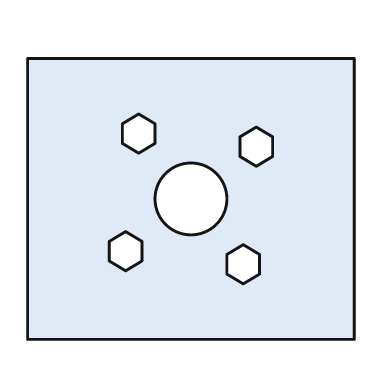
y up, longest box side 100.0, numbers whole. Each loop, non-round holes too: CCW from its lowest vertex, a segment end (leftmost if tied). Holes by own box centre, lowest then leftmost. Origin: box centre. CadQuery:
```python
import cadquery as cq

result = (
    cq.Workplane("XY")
    .moveTo(-50.0, -43.0)
    .lineTo(50.0, -43.0)
    .lineTo(50.0, 43.0)
    .lineTo(-50.0, 43.0)
    .close()
    .moveTo(16.0, -26.0)
    .lineTo(21.0, -23.0)
    .lineTo(21.0, -17.0)
    .lineTo(16.0, -14.0)
    .lineTo(11.0, -17.0)
    .lineTo(11.0, -23.0)
    .close()
    .moveTo(-20.0, -22.0)
    .lineTo(-15.0, -19.0)
    .lineTo(-15.0, -13.0)
    .lineTo(-20.0, -10.0)
    .lineTo(-25.0, -13.0)
    .lineTo(-25.0, -19.0)
    .close()
    .moveTo(0.0, 0.0)
    .circle(11.0)
    .moveTo(20.0, 10.0)
    .lineTo(25.0, 13.0)
    .lineTo(25.0, 19.0)
    .lineTo(20.0, 22.0)
    .lineTo(15.0, 19.0)
    .lineTo(15.0, 13.0)
    .close()
    .moveTo(-16.0, 14.0)
    .lineTo(-11.0, 17.0)
    .lineTo(-11.0, 23.0)
    .lineTo(-16.0, 26.0)
    .lineTo(-21.0, 23.0)
    .lineTo(-21.0, 17.0)
    .close()
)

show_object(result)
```